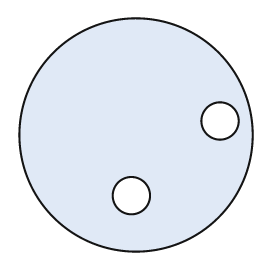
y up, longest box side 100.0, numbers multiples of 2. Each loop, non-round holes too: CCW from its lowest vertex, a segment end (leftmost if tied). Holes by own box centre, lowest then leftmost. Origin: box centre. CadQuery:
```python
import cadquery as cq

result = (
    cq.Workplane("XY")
    .moveTo(0.0, 0.0)
    .circle(50.0)
    .moveTo(-2.0, -26.0)
    .circle(8.0)
    .moveTo(36.0, 6.0)
    .circle(8.0)
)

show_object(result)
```